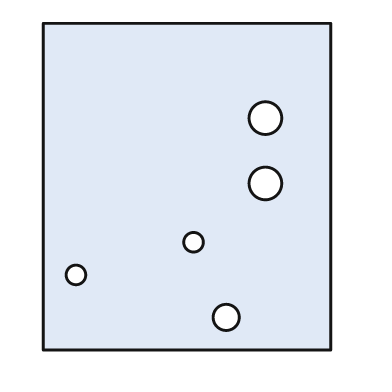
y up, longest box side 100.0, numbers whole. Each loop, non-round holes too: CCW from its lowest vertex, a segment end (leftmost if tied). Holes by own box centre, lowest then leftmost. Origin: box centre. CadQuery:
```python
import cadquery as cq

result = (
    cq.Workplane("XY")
    .moveTo(-44.0, -50.0)
    .lineTo(44.0, -50.0)
    .lineTo(44.0, 50.0)
    .lineTo(-44.0, 50.0)
    .close()
    .moveTo(12.0, -40.0)
    .circle(4.0)
    .moveTo(-34.0, -27.0)
    .circle(3.0)
    .moveTo(2.0, -17.0)
    .circle(3.0)
    .moveTo(24.0, 1.0)
    .circle(5.0)
    .moveTo(24.0, 21.0)
    .circle(5.0)
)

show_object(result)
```